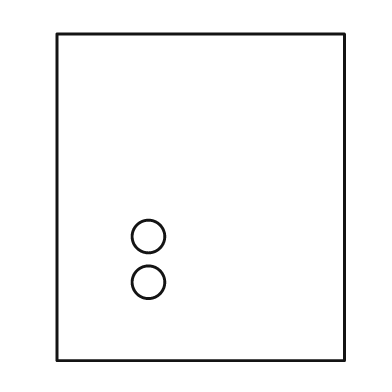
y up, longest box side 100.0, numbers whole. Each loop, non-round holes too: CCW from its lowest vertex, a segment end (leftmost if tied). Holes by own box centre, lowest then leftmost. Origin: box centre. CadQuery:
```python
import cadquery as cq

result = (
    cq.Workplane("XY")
    .moveTo(-44.0, -50.0)
    .lineTo(44.0, -50.0)
    .lineTo(44.0, 50.0)
    .lineTo(-44.0, 50.0)
    .close()
    .moveTo(-16.0, -26.0)
    .circle(5.0)
    .moveTo(-16.0, -12.0)
    .circle(5.0)
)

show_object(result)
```